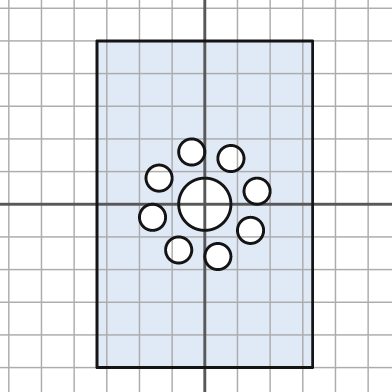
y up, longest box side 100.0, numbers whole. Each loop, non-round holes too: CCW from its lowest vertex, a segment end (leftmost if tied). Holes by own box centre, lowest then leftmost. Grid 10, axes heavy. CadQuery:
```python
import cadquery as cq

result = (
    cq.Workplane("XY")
    .moveTo(-33.0, -50.0)
    .lineTo(33.0, -50.0)
    .lineTo(33.0, 50.0)
    .lineTo(-33.0, 50.0)
    .close()
    .moveTo(4.0, -16.0)
    .circle(4.0)
    .moveTo(-8.0, -14.0)
    .circle(4.0)
    .moveTo(14.0, -8.0)
    .circle(4.0)
    .moveTo(-16.0, -4.0)
    .circle(4.0)
    .moveTo(0.0, 0.0)
    .circle(8.0)
    .moveTo(16.0, 4.0)
    .circle(4.0)
    .moveTo(-14.0, 8.0)
    .circle(4.0)
    .moveTo(8.0, 14.0)
    .circle(4.0)
    .moveTo(-4.0, 16.0)
    .circle(4.0)
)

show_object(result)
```